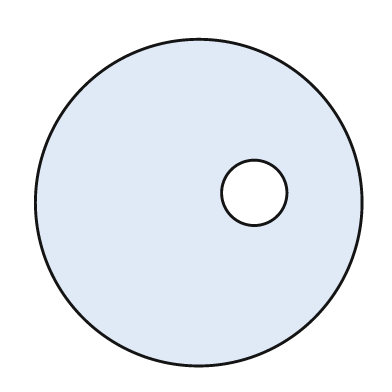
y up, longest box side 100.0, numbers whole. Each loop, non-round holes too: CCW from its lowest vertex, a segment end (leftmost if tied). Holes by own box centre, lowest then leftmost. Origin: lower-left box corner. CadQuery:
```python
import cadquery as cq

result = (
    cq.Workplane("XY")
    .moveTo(50.0, 50.0)
    .circle(50.0)
    .moveTo(67.0, 53.0)
    .circle(10.0)
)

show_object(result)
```